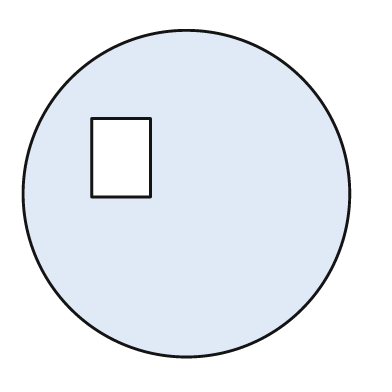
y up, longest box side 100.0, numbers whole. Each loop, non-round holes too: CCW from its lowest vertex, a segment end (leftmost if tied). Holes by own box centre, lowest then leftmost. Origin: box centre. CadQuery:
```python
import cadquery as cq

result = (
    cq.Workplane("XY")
    .moveTo(0.0, 0.0)
    .circle(50.0)
    .moveTo(-29.0, -1.0)
    .lineTo(-11.0, -1.0)
    .lineTo(-11.0, 23.0)
    .lineTo(-29.0, 23.0)
    .close()
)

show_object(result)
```